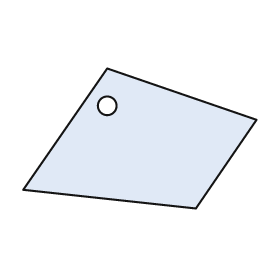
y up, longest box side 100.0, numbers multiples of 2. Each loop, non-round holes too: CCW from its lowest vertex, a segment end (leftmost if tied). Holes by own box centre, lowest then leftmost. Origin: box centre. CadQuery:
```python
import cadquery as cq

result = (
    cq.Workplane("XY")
    .moveTo(24.0, -30.0)
    .lineTo(50.0, 8.0)
    .lineTo(-14.0, 30.0)
    .lineTo(-50.0, -22.0)
    .close()
    .moveTo(-14.0, 14.0)
    .circle(4.0)
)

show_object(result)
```